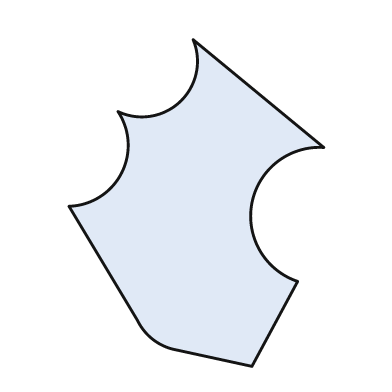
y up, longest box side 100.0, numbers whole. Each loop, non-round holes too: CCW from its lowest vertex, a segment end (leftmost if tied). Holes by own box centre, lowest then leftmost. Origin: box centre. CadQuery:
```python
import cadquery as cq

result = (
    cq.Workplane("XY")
    .moveTo(17.0, -50.0)
    .lineTo(31.0, -24.0)
    .threePointArc((17.0, 0.0), (39.0, 17.0))
    .lineTo(-1.0, 50.0)
    .threePointArc((-5.0, 31.0), (-24.0, 28.0))
    .threePointArc((-23.0, 9.0), (-39.0, -1.0))
    .lineTo(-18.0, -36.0)
    .threePointArc((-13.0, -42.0), (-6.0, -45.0))
    .close()
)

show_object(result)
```